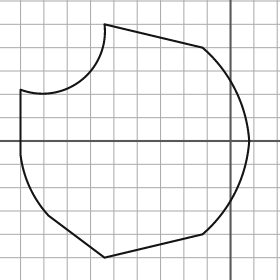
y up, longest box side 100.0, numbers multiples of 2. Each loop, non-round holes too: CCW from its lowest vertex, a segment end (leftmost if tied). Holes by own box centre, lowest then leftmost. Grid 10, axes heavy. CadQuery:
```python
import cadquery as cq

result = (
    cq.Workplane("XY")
    .moveTo(-54.0, -50.0)
    .lineTo(-12.0, -40.0)
    .threePointArc((2.0, -22.0), (8.0, 0.0))
    .threePointArc((2.0, 22.0), (-12.0, 40.0))
    .lineTo(-54.0, 50.0)
    .threePointArc((-64.0, 26.0), (-90.0, 22.0))
    .lineTo(-90.0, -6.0)
    .threePointArc((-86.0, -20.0), (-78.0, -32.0))
    .close()
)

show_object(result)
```